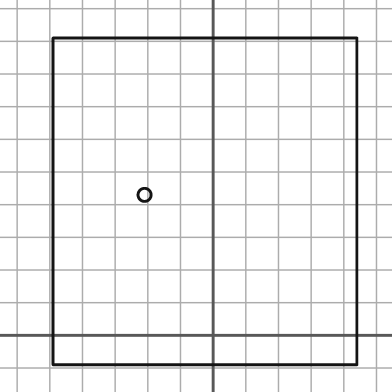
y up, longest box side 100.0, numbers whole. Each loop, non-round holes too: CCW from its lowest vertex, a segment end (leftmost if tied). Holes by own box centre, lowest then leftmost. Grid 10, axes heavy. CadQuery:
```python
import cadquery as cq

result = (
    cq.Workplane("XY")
    .moveTo(-49.0, -9.0)
    .lineTo(44.0, -9.0)
    .lineTo(44.0, 91.0)
    .lineTo(-49.0, 91.0)
    .close()
    .moveTo(-21.0, 43.0)
    .circle(2.0)
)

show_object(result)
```